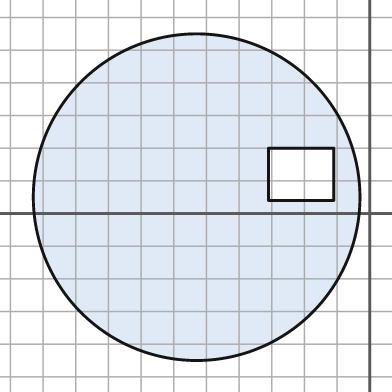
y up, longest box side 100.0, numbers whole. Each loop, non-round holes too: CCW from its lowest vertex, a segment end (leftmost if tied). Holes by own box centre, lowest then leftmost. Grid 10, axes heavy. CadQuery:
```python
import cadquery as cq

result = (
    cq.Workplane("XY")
    .moveTo(-53.0, 5.0)
    .circle(50.0)
    .moveTo(-31.0, 4.0)
    .lineTo(-11.0, 4.0)
    .lineTo(-11.0, 20.0)
    .lineTo(-31.0, 20.0)
    .close()
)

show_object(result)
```